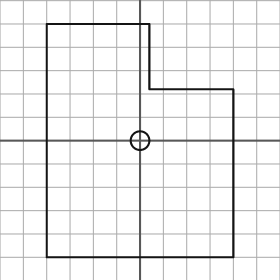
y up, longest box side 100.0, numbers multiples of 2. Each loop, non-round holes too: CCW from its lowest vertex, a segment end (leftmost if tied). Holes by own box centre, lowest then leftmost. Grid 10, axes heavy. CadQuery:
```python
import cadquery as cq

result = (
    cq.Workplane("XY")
    .moveTo(-40.0, -50.0)
    .lineTo(40.0, -50.0)
    .lineTo(40.0, 22.0)
    .lineTo(4.0, 22.0)
    .lineTo(4.0, 50.0)
    .lineTo(-40.0, 50.0)
    .close()
    .moveTo(0.0, 0.0)
    .circle(4.0)
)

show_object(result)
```